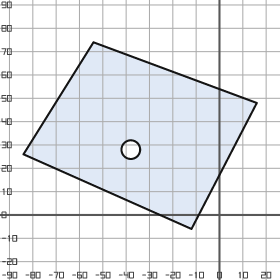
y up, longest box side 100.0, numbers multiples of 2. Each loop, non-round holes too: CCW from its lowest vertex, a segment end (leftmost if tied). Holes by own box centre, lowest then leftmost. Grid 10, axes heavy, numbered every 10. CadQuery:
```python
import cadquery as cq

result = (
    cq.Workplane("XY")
    .moveTo(-12.0, -6.0)
    .lineTo(16.0, 48.0)
    .lineTo(-54.0, 74.0)
    .lineTo(-84.0, 26.0)
    .close()
    .moveTo(-38.0, 28.0)
    .circle(4.0)
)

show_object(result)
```